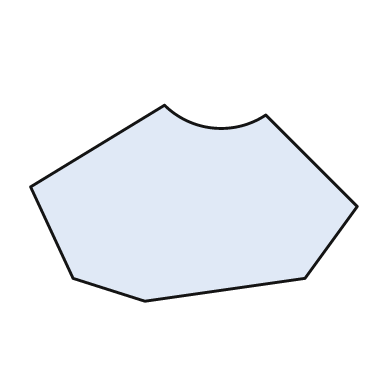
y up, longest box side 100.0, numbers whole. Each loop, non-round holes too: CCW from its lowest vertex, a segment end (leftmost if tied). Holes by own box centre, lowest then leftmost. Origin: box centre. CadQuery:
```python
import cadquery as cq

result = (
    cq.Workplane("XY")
    .moveTo(-15.0, -30.0)
    .lineTo(34.0, -23.0)
    .lineTo(50.0, -1.0)
    .lineTo(22.0, 27.0)
    .threePointArc((6.0, 23.0), (-9.0, 30.0))
    .lineTo(-50.0, 5.0)
    .lineTo(-37.0, -23.0)
    .close()
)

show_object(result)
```